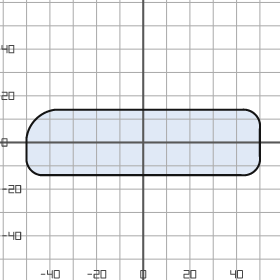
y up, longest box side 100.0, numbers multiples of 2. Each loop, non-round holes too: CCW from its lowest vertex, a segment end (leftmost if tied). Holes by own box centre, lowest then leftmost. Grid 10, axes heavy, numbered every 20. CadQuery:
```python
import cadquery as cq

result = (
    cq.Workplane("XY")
    .moveTo(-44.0, -14.0)
    .lineTo(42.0, -14.0)
    .threePointArc((48.0, -12.0), (50.0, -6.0))
    .lineTo(50.0, 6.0)
    .threePointArc((48.0, 12.0), (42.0, 14.0))
    .lineTo(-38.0, 14.0)
    .threePointArc((-46.0, 10.0), (-50.0, 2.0))
    .lineTo(-50.0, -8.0)
    .threePointArc((-48.0, -12.0), (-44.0, -14.0))
    .close()
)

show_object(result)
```